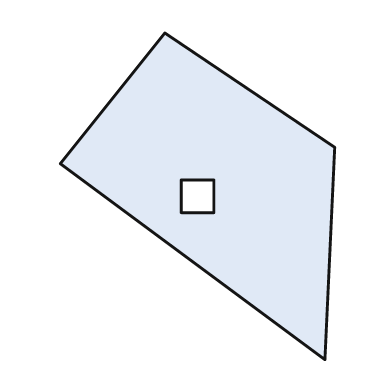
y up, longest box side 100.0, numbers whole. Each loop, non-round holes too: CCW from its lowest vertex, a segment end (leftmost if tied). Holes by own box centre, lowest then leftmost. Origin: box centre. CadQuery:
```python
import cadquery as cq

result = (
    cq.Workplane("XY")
    .moveTo(39.0, -50.0)
    .lineTo(42.0, 15.0)
    .lineTo(-10.0, 50.0)
    .lineTo(-42.0, 10.0)
    .close()
    .moveTo(-5.0, -5.0)
    .lineTo(5.0, -5.0)
    .lineTo(5.0, 5.0)
    .lineTo(-5.0, 5.0)
    .close()
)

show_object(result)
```